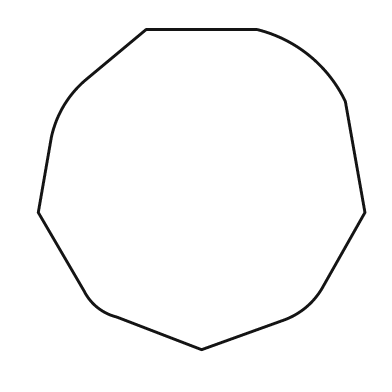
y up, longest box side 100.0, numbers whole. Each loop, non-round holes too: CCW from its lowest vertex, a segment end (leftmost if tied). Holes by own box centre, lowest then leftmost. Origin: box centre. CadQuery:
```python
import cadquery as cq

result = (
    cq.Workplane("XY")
    .moveTo(0.0, -49.0)
    .lineTo(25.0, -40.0)
    .threePointArc((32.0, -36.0), (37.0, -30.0))
    .lineTo(50.0, -7.0)
    .lineTo(44.0, 27.0)
    .threePointArc((33.0, 41.0), (17.0, 49.0))
    .lineTo(-17.0, 49.0)
    .lineTo(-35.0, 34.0)
    .threePointArc((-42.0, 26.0), (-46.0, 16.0))
    .lineTo(-50.0, -7.0)
    .lineTo(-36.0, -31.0)
    .threePointArc((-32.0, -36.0), (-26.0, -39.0))
    .close()
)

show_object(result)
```